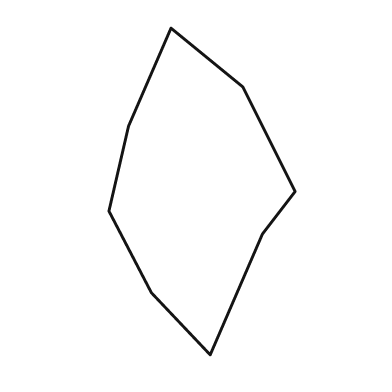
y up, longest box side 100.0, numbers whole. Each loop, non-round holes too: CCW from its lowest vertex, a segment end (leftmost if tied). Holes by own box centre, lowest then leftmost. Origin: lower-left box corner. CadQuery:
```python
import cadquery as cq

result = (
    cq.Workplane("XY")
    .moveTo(31.0, 0.0)
    .lineTo(47.0, 37.0)
    .lineTo(57.0, 50.0)
    .lineTo(41.0, 82.0)
    .lineTo(19.0, 100.0)
    .lineTo(6.0, 70.0)
    .lineTo(0.0, 44.0)
    .lineTo(13.0, 19.0)
    .close()
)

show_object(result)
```